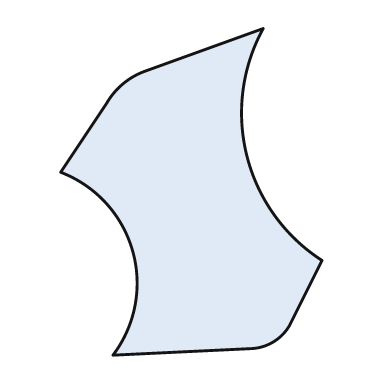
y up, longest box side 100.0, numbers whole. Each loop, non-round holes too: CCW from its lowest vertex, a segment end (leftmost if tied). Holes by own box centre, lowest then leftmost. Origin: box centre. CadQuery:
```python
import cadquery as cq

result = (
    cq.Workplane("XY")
    .moveTo(-24.0, -50.0)
    .lineTo(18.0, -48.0)
    .threePointArc((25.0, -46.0), (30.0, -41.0))
    .lineTo(40.0, -21.0)
    .threePointArc((17.0, 11.0), (22.0, 50.0))
    .lineTo(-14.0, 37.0)
    .threePointArc((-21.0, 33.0), (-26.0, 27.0))
    .lineTo(-40.0, 6.0)
    .threePointArc((-18.0, -18.0), (-24.0, -50.0))
    .close()
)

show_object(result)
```